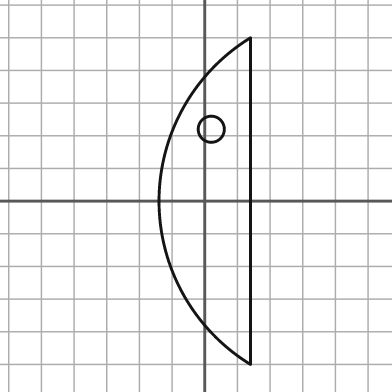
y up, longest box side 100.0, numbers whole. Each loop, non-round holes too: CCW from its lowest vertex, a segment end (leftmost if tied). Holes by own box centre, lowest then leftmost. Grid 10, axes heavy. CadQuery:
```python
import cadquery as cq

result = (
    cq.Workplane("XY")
    .moveTo(14.0, -50.0)
    .lineTo(14.0, 50.0)
    .threePointArc((-14.0, 0.0), (14.0, -50.0))
    .close()
    .moveTo(2.0, 22.0)
    .circle(4.0)
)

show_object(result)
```